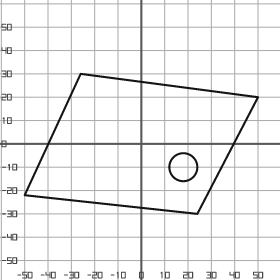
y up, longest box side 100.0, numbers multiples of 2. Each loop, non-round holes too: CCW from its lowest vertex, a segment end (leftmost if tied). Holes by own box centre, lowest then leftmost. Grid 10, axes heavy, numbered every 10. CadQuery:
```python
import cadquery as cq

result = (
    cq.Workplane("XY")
    .moveTo(24.0, -30.0)
    .lineTo(50.0, 20.0)
    .lineTo(-26.0, 30.0)
    .lineTo(-50.0, -22.0)
    .close()
    .moveTo(18.0, -10.0)
    .circle(6.0)
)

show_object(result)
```